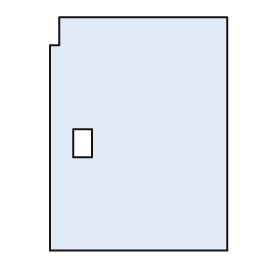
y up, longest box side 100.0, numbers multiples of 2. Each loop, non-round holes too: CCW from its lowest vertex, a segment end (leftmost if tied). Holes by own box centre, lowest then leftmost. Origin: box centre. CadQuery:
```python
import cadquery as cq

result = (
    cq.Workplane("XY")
    .moveTo(-38.0, -50.0)
    .lineTo(38.0, -50.0)
    .lineTo(38.0, 50.0)
    .lineTo(-34.0, 50.0)
    .lineTo(-34.0, 38.0)
    .lineTo(-38.0, 38.0)
    .close()
    .moveTo(-28.0, -10.0)
    .lineTo(-20.0, -10.0)
    .lineTo(-20.0, 2.0)
    .lineTo(-28.0, 2.0)
    .close()
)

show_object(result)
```